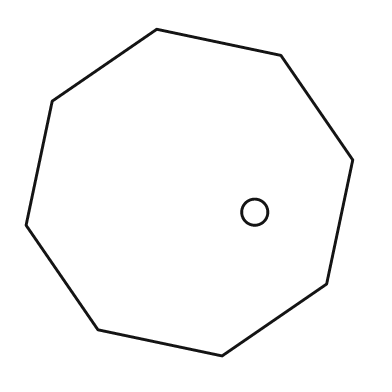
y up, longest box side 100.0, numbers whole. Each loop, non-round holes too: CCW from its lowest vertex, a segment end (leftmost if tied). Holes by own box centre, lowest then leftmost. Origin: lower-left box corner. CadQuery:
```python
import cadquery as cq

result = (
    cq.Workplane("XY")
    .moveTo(60.0, 0.0)
    .lineTo(92.0, 22.0)
    .lineTo(100.0, 60.0)
    .lineTo(78.0, 92.0)
    .lineTo(40.0, 100.0)
    .lineTo(8.0, 78.0)
    .lineTo(0.0, 40.0)
    .lineTo(22.0, 8.0)
    .close()
    .moveTo(70.0, 44.0)
    .circle(4.0)
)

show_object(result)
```